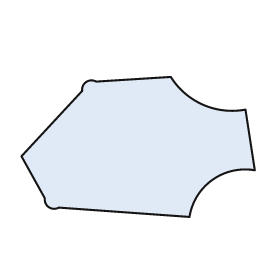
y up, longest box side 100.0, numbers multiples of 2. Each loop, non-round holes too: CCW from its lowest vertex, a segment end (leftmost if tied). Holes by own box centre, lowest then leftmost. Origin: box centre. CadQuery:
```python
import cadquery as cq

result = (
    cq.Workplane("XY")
    .moveTo(22.0, -30.0)
    .threePointArc((32.0, -14.0), (50.0, -10.0))
    .lineTo(46.0, 16.0)
    .threePointArc((28.0, 18.0), (14.0, 30.0))
    .lineTo(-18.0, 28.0)
    .threePointArc((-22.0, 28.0), (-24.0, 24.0))
    .lineTo(-50.0, -4.0)
    .lineTo(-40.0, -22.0)
    .threePointArc((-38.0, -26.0), (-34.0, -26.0))
    .close()
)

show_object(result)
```